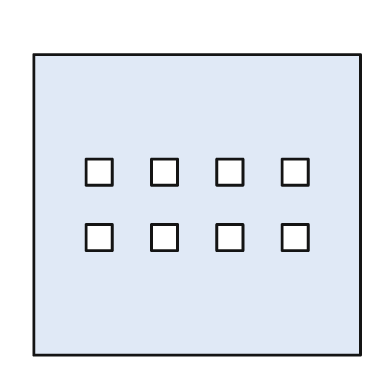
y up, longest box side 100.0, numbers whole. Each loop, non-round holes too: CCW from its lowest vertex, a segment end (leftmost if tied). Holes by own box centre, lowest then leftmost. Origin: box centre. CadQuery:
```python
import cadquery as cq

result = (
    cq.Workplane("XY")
    .moveTo(-50.0, -46.0)
    .lineTo(50.0, -46.0)
    .lineTo(50.0, 46.0)
    .lineTo(-50.0, 46.0)
    .close()
    .moveTo(-34.0, -14.0)
    .lineTo(-26.0, -14.0)
    .lineTo(-26.0, -6.0)
    .lineTo(-34.0, -6.0)
    .close()
    .moveTo(-14.0, -14.0)
    .lineTo(-6.0, -14.0)
    .lineTo(-6.0, -6.0)
    .lineTo(-14.0, -6.0)
    .close()
    .moveTo(6.0, -14.0)
    .lineTo(14.0, -14.0)
    .lineTo(14.0, -6.0)
    .lineTo(6.0, -6.0)
    .close()
    .moveTo(26.0, -14.0)
    .lineTo(34.0, -14.0)
    .lineTo(34.0, -6.0)
    .lineTo(26.0, -6.0)
    .close()
    .moveTo(-34.0, 6.0)
    .lineTo(-26.0, 6.0)
    .lineTo(-26.0, 14.0)
    .lineTo(-34.0, 14.0)
    .close()
    .moveTo(-14.0, 6.0)
    .lineTo(-6.0, 6.0)
    .lineTo(-6.0, 14.0)
    .lineTo(-14.0, 14.0)
    .close()
    .moveTo(6.0, 6.0)
    .lineTo(14.0, 6.0)
    .lineTo(14.0, 14.0)
    .lineTo(6.0, 14.0)
    .close()
    .moveTo(26.0, 6.0)
    .lineTo(34.0, 6.0)
    .lineTo(34.0, 14.0)
    .lineTo(26.0, 14.0)
    .close()
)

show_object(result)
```